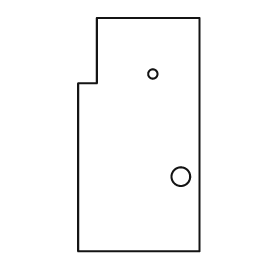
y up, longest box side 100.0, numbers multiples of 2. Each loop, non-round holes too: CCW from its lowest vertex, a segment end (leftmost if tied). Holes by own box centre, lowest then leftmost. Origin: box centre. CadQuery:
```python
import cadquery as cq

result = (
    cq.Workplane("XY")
    .moveTo(-26.0, -50.0)
    .lineTo(26.0, -50.0)
    .lineTo(26.0, 50.0)
    .lineTo(-18.0, 50.0)
    .lineTo(-18.0, 22.0)
    .lineTo(-26.0, 22.0)
    .close()
    .moveTo(18.0, -18.0)
    .circle(4.0)
    .moveTo(6.0, 26.0)
    .circle(2.0)
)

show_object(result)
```